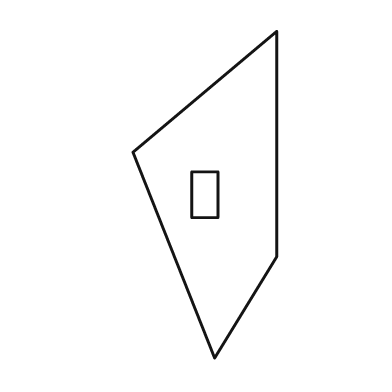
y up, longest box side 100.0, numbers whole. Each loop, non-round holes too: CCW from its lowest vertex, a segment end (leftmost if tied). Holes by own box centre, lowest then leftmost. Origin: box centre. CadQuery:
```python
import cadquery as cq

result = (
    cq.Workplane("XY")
    .moveTo(3.0, -50.0)
    .lineTo(22.0, -19.0)
    .lineTo(22.0, 50.0)
    .lineTo(-22.0, 13.0)
    .close()
    .moveTo(-4.0, -7.0)
    .lineTo(4.0, -7.0)
    .lineTo(4.0, 7.0)
    .lineTo(-4.0, 7.0)
    .close()
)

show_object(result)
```